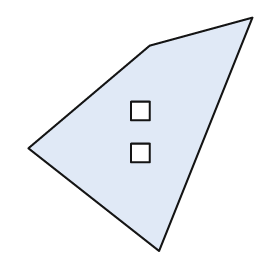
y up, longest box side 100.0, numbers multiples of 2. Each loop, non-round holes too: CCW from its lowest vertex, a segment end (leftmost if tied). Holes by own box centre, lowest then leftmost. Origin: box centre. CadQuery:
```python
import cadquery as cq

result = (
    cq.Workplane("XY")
    .moveTo(8.0, -50.0)
    .lineTo(48.0, 50.0)
    .lineTo(4.0, 38.0)
    .lineTo(-48.0, -6.0)
    .close()
    .moveTo(-4.0, -12.0)
    .lineTo(4.0, -12.0)
    .lineTo(4.0, -4.0)
    .lineTo(-4.0, -4.0)
    .close()
    .moveTo(-4.0, 6.0)
    .lineTo(4.0, 6.0)
    .lineTo(4.0, 14.0)
    .lineTo(-4.0, 14.0)
    .close()
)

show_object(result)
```